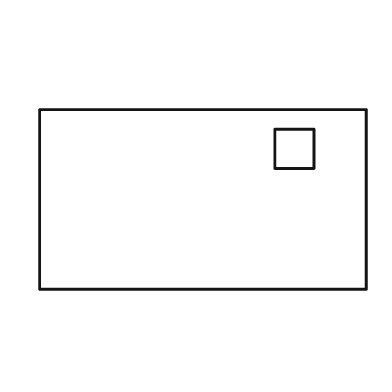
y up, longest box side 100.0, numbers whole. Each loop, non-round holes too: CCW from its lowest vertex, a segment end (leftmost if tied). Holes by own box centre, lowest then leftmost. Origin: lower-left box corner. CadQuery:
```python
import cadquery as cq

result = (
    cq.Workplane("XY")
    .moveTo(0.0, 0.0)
    .lineTo(100.0, 0.0)
    .lineTo(100.0, 55.0)
    .lineTo(0.0, 55.0)
    .close()
    .moveTo(72.0, 37.0)
    .lineTo(84.0, 37.0)
    .lineTo(84.0, 49.0)
    .lineTo(72.0, 49.0)
    .close()
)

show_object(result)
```